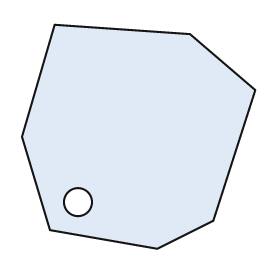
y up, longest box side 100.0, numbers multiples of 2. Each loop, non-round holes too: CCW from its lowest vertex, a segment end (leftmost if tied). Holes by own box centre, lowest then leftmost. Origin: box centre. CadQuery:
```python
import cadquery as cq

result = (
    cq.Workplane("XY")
    .moveTo(8.0, -48.0)
    .lineTo(32.0, -36.0)
    .lineTo(50.0, 20.0)
    .lineTo(22.0, 44.0)
    .lineTo(-36.0, 48.0)
    .lineTo(-50.0, 0.0)
    .lineTo(-38.0, -40.0)
    .close()
    .moveTo(-26.0, -28.0)
    .circle(6.0)
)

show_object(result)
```